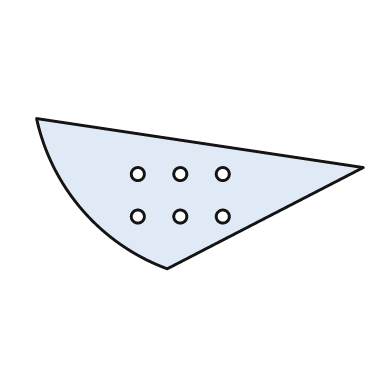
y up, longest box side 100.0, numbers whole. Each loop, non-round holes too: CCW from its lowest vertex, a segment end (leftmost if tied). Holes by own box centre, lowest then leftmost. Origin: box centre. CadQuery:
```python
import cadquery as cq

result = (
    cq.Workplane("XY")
    .moveTo(-10.0, -23.0)
    .lineTo(50.0, 8.0)
    .lineTo(-50.0, 23.0)
    .threePointArc((-36.0, -5.0), (-10.0, -23.0))
    .close()
    .moveTo(-19.0, -7.0)
    .circle(2.0)
    .moveTo(-6.0, -7.0)
    .circle(2.0)
    .moveTo(7.0, -7.0)
    .circle(2.0)
    .moveTo(-19.0, 6.0)
    .circle(2.0)
    .moveTo(-6.0, 6.0)
    .circle(2.0)
    .moveTo(7.0, 6.0)
    .circle(2.0)
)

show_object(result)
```